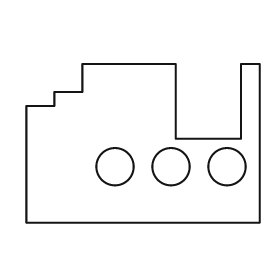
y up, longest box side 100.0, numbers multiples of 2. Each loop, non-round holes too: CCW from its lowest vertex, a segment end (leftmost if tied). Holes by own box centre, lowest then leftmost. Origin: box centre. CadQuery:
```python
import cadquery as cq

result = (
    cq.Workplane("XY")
    .moveTo(-50.0, -34.0)
    .lineTo(50.0, -34.0)
    .lineTo(50.0, 34.0)
    .lineTo(42.0, 34.0)
    .lineTo(42.0, 2.0)
    .lineTo(14.0, 2.0)
    .lineTo(14.0, 34.0)
    .lineTo(-26.0, 34.0)
    .lineTo(-26.0, 22.0)
    .lineTo(-38.0, 22.0)
    .lineTo(-38.0, 16.0)
    .lineTo(-50.0, 16.0)
    .close()
    .moveTo(-12.0, -10.0)
    .circle(8.0)
    .moveTo(12.0, -10.0)
    .circle(8.0)
    .moveTo(36.0, -10.0)
    .circle(8.0)
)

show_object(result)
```